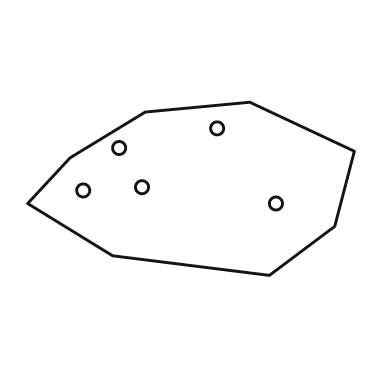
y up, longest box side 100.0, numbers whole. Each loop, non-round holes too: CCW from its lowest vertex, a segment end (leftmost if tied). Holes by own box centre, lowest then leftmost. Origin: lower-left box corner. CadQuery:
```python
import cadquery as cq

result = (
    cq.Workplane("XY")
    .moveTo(74.0, 0.0)
    .lineTo(94.0, 15.0)
    .lineTo(100.0, 38.0)
    .lineTo(68.0, 53.0)
    .lineTo(36.0, 50.0)
    .lineTo(13.0, 36.0)
    .lineTo(0.0, 22.0)
    .lineTo(26.0, 6.0)
    .close()
    .moveTo(76.0, 22.0)
    .circle(2.0)
    .moveTo(17.0, 26.0)
    .circle(2.0)
    .moveTo(35.0, 27.0)
    .circle(2.0)
    .moveTo(28.0, 39.0)
    .circle(2.0)
    .moveTo(58.0, 45.0)
    .circle(2.0)
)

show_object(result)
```